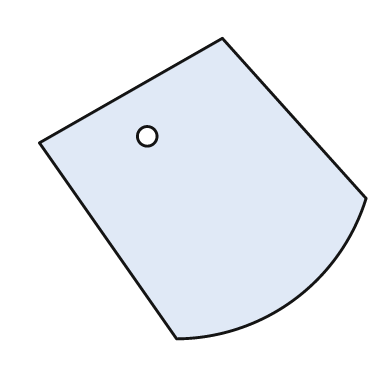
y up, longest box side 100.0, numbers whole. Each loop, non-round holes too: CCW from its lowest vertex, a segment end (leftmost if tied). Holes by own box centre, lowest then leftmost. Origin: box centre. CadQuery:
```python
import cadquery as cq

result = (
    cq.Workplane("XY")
    .moveTo(-8.0, -46.0)
    .threePointArc((28.0, -34.0), (50.0, -3.0))
    .lineTo(6.0, 46.0)
    .lineTo(-50.0, 14.0)
    .close()
    .moveTo(-17.0, 16.0)
    .circle(3.0)
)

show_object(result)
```